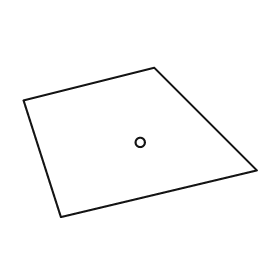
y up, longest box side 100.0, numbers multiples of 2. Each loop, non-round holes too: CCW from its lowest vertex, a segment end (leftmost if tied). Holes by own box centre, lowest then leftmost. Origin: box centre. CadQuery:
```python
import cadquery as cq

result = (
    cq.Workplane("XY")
    .moveTo(-34.0, -32.0)
    .lineTo(50.0, -12.0)
    .lineTo(6.0, 32.0)
    .lineTo(-50.0, 18.0)
    .close()
    .moveTo(0.0, 0.0)
    .circle(2.0)
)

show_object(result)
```